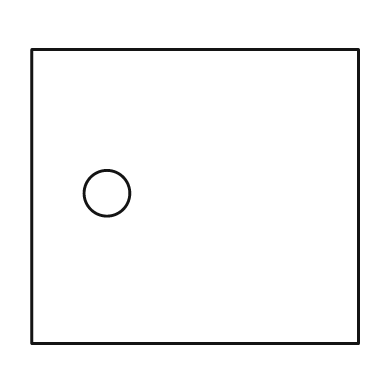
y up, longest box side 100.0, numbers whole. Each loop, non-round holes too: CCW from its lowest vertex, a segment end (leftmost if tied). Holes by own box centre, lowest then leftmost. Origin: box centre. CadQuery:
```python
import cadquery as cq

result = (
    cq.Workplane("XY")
    .moveTo(-50.0, -45.0)
    .lineTo(50.0, -45.0)
    .lineTo(50.0, 45.0)
    .lineTo(-50.0, 45.0)
    .close()
    .moveTo(-27.0, 1.0)
    .circle(7.0)
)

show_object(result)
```